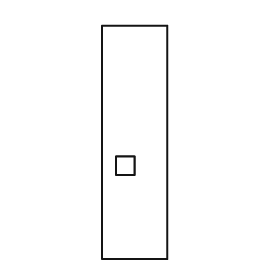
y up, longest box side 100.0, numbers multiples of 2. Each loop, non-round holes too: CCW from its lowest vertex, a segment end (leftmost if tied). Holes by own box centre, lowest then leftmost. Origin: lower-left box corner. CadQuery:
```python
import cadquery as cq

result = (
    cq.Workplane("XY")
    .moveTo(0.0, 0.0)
    .lineTo(28.0, 0.0)
    .lineTo(28.0, 100.0)
    .lineTo(0.0, 100.0)
    .close()
    .moveTo(6.0, 36.0)
    .lineTo(14.0, 36.0)
    .lineTo(14.0, 44.0)
    .lineTo(6.0, 44.0)
    .close()
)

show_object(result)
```